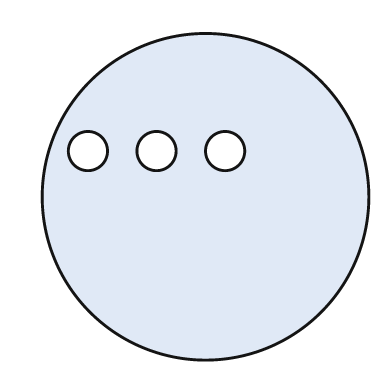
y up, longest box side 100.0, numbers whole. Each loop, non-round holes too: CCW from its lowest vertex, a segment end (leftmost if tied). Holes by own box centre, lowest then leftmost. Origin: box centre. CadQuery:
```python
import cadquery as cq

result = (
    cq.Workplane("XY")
    .moveTo(0.0, 0.0)
    .circle(50.0)
    .moveTo(-36.0, 14.0)
    .circle(6.0)
    .moveTo(-15.0, 14.0)
    .circle(6.0)
    .moveTo(6.0, 14.0)
    .circle(6.0)
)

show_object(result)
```